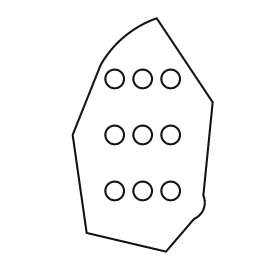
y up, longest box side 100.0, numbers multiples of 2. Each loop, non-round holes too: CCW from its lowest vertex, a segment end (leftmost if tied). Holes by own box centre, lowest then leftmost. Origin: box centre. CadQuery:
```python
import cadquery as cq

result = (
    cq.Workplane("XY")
    .moveTo(10.0, -50.0)
    .lineTo(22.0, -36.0)
    .threePointArc((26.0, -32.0), (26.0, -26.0))
    .lineTo(30.0, 14.0)
    .lineTo(6.0, 50.0)
    .threePointArc((-8.0, 42.0), (-18.0, 30.0))
    .lineTo(-30.0, 0.0)
    .lineTo(-24.0, -42.0)
    .close()
    .moveTo(-12.0, -24.0)
    .circle(4.0)
    .moveTo(0.0, -24.0)
    .circle(4.0)
    .moveTo(12.0, -24.0)
    .circle(4.0)
    .moveTo(-12.0, 0.0)
    .circle(4.0)
    .moveTo(0.0, 0.0)
    .circle(4.0)
    .moveTo(12.0, 0.0)
    .circle(4.0)
    .moveTo(-12.0, 24.0)
    .circle(4.0)
    .moveTo(0.0, 24.0)
    .circle(4.0)
    .moveTo(12.0, 24.0)
    .circle(4.0)
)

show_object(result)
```